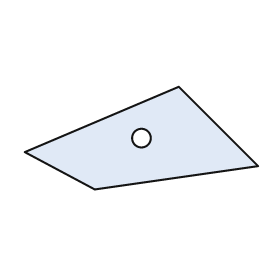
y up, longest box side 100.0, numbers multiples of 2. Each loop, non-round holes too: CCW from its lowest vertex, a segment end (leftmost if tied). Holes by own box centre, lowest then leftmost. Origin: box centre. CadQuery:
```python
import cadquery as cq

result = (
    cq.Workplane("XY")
    .moveTo(-20.0, -22.0)
    .lineTo(50.0, -12.0)
    .lineTo(16.0, 22.0)
    .lineTo(-50.0, -6.0)
    .close()
    .moveTo(0.0, 0.0)
    .circle(4.0)
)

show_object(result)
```